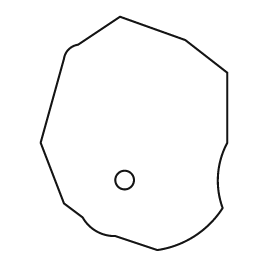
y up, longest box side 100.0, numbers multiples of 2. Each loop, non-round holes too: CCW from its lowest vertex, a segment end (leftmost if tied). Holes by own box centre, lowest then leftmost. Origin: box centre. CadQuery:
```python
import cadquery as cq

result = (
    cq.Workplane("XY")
    .moveTo(10.0, -50.0)
    .threePointArc((26.0, -44.0), (38.0, -32.0))
    .threePointArc((36.0, -18.0), (40.0, -4.0))
    .lineTo(40.0, 26.0)
    .lineTo(22.0, 40.0)
    .lineTo(-6.0, 50.0)
    .lineTo(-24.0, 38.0)
    .threePointArc((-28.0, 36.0), (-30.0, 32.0))
    .lineTo(-40.0, -4.0)
    .lineTo(-30.0, -30.0)
    .lineTo(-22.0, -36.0)
    .threePointArc((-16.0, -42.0), (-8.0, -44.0))
    .close()
    .moveTo(-4.0, -20.0)
    .circle(4.0)
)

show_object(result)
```